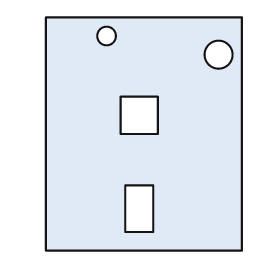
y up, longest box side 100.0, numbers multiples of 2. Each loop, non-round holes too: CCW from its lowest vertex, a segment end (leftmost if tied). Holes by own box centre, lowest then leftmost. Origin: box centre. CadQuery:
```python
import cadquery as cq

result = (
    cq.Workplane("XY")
    .moveTo(-42.0, -50.0)
    .lineTo(42.0, -50.0)
    .lineTo(42.0, 50.0)
    .lineTo(-42.0, 50.0)
    .close()
    .moveTo(-8.0, -42.0)
    .lineTo(4.0, -42.0)
    .lineTo(4.0, -22.0)
    .lineTo(-8.0, -22.0)
    .close()
    .moveTo(-10.0, 0.0)
    .lineTo(6.0, 0.0)
    .lineTo(6.0, 16.0)
    .lineTo(-10.0, 16.0)
    .close()
    .moveTo(32.0, 34.0)
    .circle(6.0)
    .moveTo(-16.0, 42.0)
    .circle(4.0)
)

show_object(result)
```